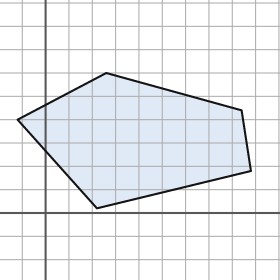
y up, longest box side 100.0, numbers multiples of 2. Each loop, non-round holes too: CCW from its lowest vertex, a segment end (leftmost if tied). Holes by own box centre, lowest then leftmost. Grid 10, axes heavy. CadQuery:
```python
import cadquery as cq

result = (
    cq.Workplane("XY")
    .moveTo(22.0, 2.0)
    .lineTo(88.0, 18.0)
    .lineTo(84.0, 44.0)
    .lineTo(26.0, 60.0)
    .lineTo(-12.0, 40.0)
    .close()
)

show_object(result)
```